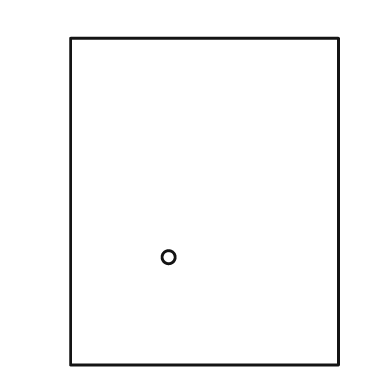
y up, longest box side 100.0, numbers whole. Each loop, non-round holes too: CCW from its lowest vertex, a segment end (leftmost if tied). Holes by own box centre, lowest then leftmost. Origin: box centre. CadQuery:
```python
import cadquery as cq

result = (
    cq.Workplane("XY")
    .moveTo(-41.0, -50.0)
    .lineTo(41.0, -50.0)
    .lineTo(41.0, 50.0)
    .lineTo(-41.0, 50.0)
    .close()
    .moveTo(-11.0, -17.0)
    .circle(2.0)
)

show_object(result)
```